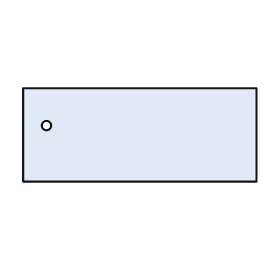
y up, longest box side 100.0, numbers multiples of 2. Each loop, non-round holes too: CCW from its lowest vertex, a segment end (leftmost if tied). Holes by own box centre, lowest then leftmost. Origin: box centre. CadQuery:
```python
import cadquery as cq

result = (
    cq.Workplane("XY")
    .moveTo(-50.0, -20.0)
    .lineTo(50.0, -20.0)
    .lineTo(50.0, 20.0)
    .lineTo(-50.0, 20.0)
    .close()
    .moveTo(-40.0, 4.0)
    .circle(2.0)
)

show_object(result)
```